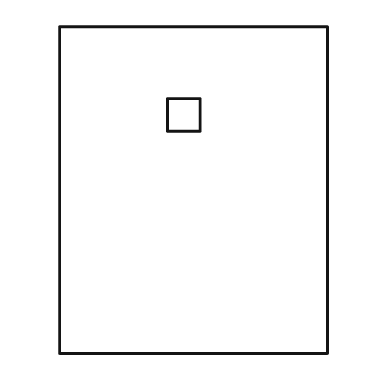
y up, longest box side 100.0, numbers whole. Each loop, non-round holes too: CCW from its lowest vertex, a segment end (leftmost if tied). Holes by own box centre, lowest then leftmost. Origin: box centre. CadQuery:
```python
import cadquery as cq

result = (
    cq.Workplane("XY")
    .moveTo(-41.0, -50.0)
    .lineTo(41.0, -50.0)
    .lineTo(41.0, 50.0)
    .lineTo(-41.0, 50.0)
    .close()
    .moveTo(-8.0, 18.0)
    .lineTo(2.0, 18.0)
    .lineTo(2.0, 28.0)
    .lineTo(-8.0, 28.0)
    .close()
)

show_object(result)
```